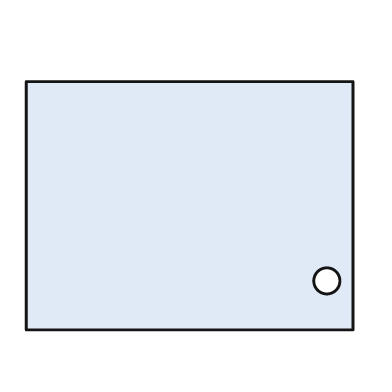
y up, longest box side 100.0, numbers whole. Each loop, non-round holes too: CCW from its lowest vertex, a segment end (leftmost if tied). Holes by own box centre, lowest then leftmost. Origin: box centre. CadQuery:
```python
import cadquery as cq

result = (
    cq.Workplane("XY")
    .moveTo(-50.0, -38.0)
    .lineTo(50.0, -38.0)
    .lineTo(50.0, 38.0)
    .lineTo(-50.0, 38.0)
    .close()
    .moveTo(42.0, -23.0)
    .circle(4.0)
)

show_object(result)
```